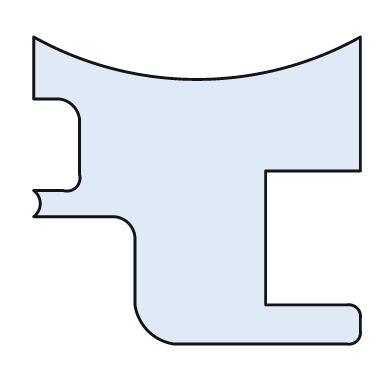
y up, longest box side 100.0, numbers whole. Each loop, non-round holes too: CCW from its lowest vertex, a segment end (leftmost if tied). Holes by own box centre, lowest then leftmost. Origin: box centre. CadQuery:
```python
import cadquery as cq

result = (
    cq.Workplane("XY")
    .moveTo(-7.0, -47.0)
    .lineTo(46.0, -47.0)
    .threePointArc((49.0, -46.0), (50.0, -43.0))
    .lineTo(50.0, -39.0)
    .threePointArc((49.0, -36.0), (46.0, -35.0))
    .lineTo(21.0, -35.0)
    .lineTo(21.0, 6.0)
    .lineTo(50.0, 6.0)
    .lineTo(50.0, 47.0)
    .threePointArc((0.0, 34.0), (-50.0, 47.0))
    .lineTo(-50.0, 28.0)
    .lineTo(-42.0, 28.0)
    .threePointArc((-38.0, 26.0), (-36.0, 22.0))
    .lineTo(-36.0, 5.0)
    .threePointArc((-37.0, 1.0), (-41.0, 0.0))
    .lineTo(-50.0, 0.0)
    .threePointArc((-48.0, -4.0), (-50.0, -8.0))
    .lineTo(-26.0, -8.0)
    .threePointArc((-21.0, -10.0), (-19.0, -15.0))
    .lineTo(-19.0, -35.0)
    .threePointArc((-15.0, -43.0), (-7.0, -47.0))
    .close()
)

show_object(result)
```